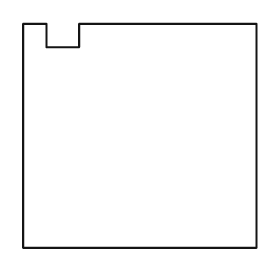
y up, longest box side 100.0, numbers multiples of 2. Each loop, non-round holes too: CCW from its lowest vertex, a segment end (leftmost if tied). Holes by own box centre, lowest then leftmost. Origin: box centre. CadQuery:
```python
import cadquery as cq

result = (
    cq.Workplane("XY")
    .moveTo(-50.0, -48.0)
    .lineTo(50.0, -48.0)
    .lineTo(50.0, 48.0)
    .lineTo(-26.0, 48.0)
    .lineTo(-26.0, 38.0)
    .lineTo(-40.0, 38.0)
    .lineTo(-40.0, 48.0)
    .lineTo(-50.0, 48.0)
    .close()
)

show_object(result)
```